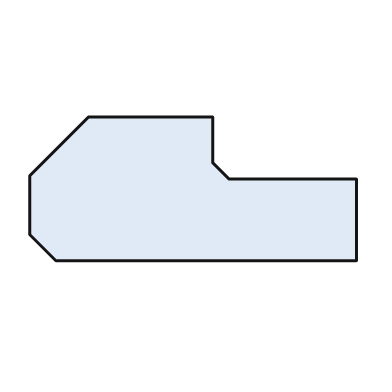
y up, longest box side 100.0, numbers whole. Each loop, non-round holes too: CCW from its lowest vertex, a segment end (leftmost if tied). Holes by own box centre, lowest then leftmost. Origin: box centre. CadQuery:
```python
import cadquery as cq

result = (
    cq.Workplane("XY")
    .moveTo(-42.0, -22.0)
    .lineTo(50.0, -22.0)
    .lineTo(50.0, 3.0)
    .lineTo(11.0, 3.0)
    .lineTo(6.0, 8.0)
    .lineTo(6.0, 22.0)
    .lineTo(-32.0, 22.0)
    .lineTo(-50.0, 4.0)
    .lineTo(-50.0, -14.0)
    .close()
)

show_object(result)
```